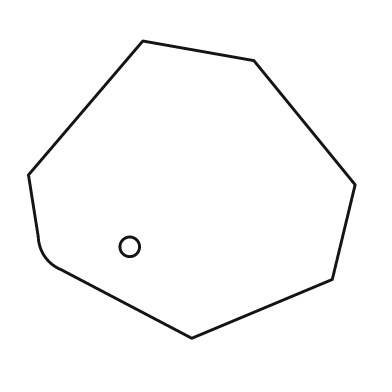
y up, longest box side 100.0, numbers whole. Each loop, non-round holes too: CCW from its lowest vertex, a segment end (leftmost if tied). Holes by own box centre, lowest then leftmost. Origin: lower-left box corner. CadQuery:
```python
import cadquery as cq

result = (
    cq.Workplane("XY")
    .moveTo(50.0, 0.0)
    .lineTo(93.0, 18.0)
    .lineTo(100.0, 47.0)
    .lineTo(69.0, 85.0)
    .lineTo(35.0, 91.0)
    .lineTo(0.0, 50.0)
    .lineTo(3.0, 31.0)
    .threePointArc((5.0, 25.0), (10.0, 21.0))
    .close()
    .moveTo(31.0, 28.0)
    .circle(3.0)
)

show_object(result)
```